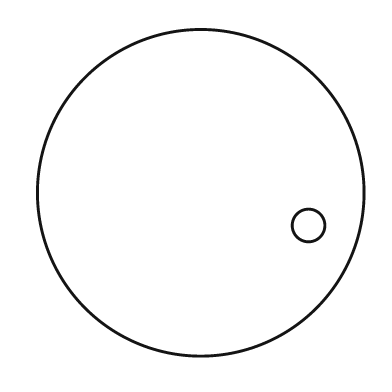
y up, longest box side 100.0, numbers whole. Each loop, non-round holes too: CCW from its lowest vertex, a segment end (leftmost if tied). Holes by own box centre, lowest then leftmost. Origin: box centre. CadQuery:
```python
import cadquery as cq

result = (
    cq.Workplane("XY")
    .moveTo(0.0, 0.0)
    .circle(50.0)
    .moveTo(33.0, -10.0)
    .circle(5.0)
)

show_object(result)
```